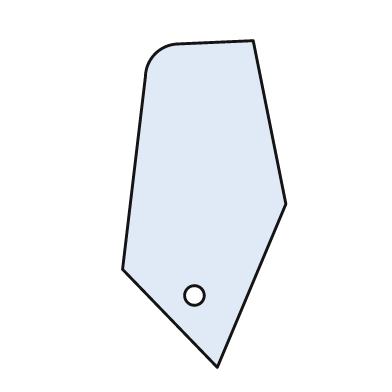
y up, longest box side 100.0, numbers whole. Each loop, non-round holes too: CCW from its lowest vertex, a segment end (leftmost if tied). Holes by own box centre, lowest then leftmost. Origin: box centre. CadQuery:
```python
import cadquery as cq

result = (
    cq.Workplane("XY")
    .moveTo(4.0, -50.0)
    .lineTo(25.0, 0.0)
    .lineTo(15.0, 50.0)
    .lineTo(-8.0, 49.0)
    .threePointArc((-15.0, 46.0), (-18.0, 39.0))
    .lineTo(-25.0, -20.0)
    .close()
    .moveTo(-3.0, -28.0)
    .circle(3.0)
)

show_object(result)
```